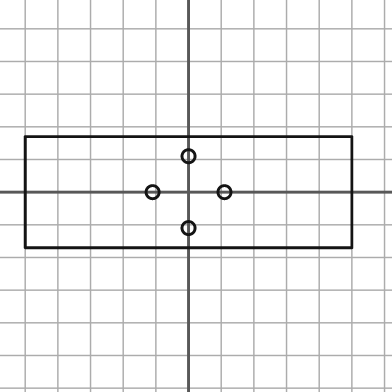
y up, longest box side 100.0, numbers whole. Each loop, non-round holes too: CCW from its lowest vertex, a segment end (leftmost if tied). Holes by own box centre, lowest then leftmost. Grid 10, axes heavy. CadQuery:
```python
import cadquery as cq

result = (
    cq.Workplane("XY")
    .moveTo(-50.0, -17.0)
    .lineTo(50.0, -17.0)
    .lineTo(50.0, 17.0)
    .lineTo(-50.0, 17.0)
    .close()
    .moveTo(0.0, -11.0)
    .circle(2.0)
    .moveTo(-11.0, 0.0)
    .circle(2.0)
    .moveTo(11.0, 0.0)
    .circle(2.0)
    .moveTo(0.0, 11.0)
    .circle(2.0)
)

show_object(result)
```